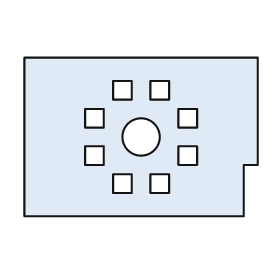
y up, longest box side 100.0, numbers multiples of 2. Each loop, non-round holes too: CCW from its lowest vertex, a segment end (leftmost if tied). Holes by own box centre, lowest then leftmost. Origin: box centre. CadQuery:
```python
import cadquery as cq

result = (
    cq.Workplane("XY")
    .moveTo(-50.0, -34.0)
    .lineTo(44.0, -34.0)
    .lineTo(44.0, -12.0)
    .lineTo(50.0, -12.0)
    .lineTo(50.0, 34.0)
    .lineTo(-50.0, 34.0)
    .close()
    .moveTo(-12.0, -24.0)
    .lineTo(-4.0, -24.0)
    .lineTo(-4.0, -16.0)
    .lineTo(-12.0, -16.0)
    .close()
    .moveTo(4.0, -24.0)
    .lineTo(12.0, -24.0)
    .lineTo(12.0, -16.0)
    .lineTo(4.0, -16.0)
    .close()
    .moveTo(-24.0, -12.0)
    .lineTo(-16.0, -12.0)
    .lineTo(-16.0, -4.0)
    .lineTo(-24.0, -4.0)
    .close()
    .moveTo(16.0, -12.0)
    .lineTo(24.0, -12.0)
    .lineTo(24.0, -4.0)
    .lineTo(16.0, -4.0)
    .close()
    .moveTo(0.0, 0.0)
    .circle(8.0)
    .moveTo(-24.0, 4.0)
    .lineTo(-16.0, 4.0)
    .lineTo(-16.0, 12.0)
    .lineTo(-24.0, 12.0)
    .close()
    .moveTo(16.0, 4.0)
    .lineTo(24.0, 4.0)
    .lineTo(24.0, 12.0)
    .lineTo(16.0, 12.0)
    .close()
    .moveTo(-12.0, 16.0)
    .lineTo(-4.0, 16.0)
    .lineTo(-4.0, 24.0)
    .lineTo(-12.0, 24.0)
    .close()
    .moveTo(4.0, 16.0)
    .lineTo(12.0, 16.0)
    .lineTo(12.0, 24.0)
    .lineTo(4.0, 24.0)
    .close()
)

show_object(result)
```